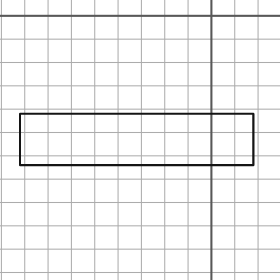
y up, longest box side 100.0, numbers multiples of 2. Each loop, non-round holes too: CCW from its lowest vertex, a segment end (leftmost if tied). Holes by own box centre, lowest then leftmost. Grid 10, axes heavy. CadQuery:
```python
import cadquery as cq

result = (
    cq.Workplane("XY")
    .moveTo(-82.0, -64.0)
    .lineTo(18.0, -64.0)
    .lineTo(18.0, -42.0)
    .lineTo(-82.0, -42.0)
    .close()
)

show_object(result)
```